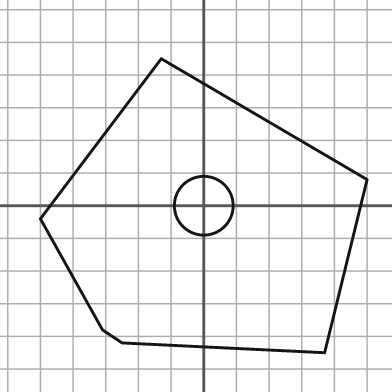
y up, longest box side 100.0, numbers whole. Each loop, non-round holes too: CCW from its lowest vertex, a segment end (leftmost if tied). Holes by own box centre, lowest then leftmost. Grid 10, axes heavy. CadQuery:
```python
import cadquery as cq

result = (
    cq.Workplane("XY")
    .moveTo(37.0, -45.0)
    .lineTo(50.0, 8.0)
    .lineTo(-13.0, 45.0)
    .lineTo(-50.0, -4.0)
    .lineTo(-31.0, -38.0)
    .lineTo(-25.0, -42.0)
    .close()
    .moveTo(0.0, 0.0)
    .circle(9.0)
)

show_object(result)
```